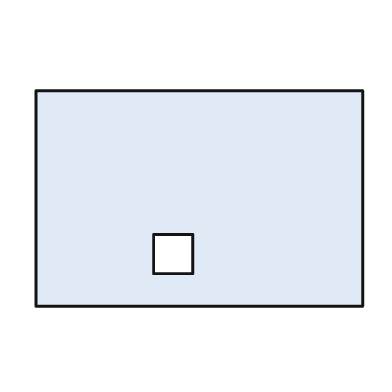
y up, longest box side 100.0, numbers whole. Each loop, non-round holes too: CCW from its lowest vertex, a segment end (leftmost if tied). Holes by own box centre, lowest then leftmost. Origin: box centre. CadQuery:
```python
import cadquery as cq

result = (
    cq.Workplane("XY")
    .moveTo(-50.0, -33.0)
    .lineTo(50.0, -33.0)
    .lineTo(50.0, 33.0)
    .lineTo(-50.0, 33.0)
    .close()
    .moveTo(-14.0, -23.0)
    .lineTo(-2.0, -23.0)
    .lineTo(-2.0, -11.0)
    .lineTo(-14.0, -11.0)
    .close()
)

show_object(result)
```